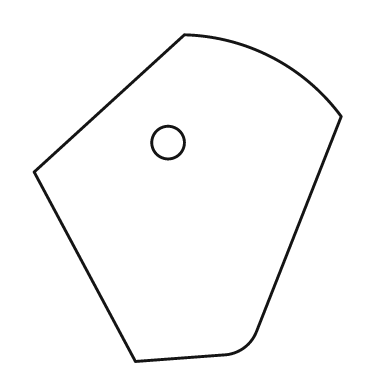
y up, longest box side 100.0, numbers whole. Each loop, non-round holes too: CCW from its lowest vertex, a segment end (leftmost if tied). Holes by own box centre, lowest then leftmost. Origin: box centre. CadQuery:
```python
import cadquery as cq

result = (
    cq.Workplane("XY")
    .moveTo(-16.0, -50.0)
    .lineTo(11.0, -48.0)
    .threePointArc((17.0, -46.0), (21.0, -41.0))
    .lineTo(47.0, 25.0)
    .threePointArc((26.0, 43.0), (-1.0, 50.0))
    .lineTo(-47.0, 8.0)
    .close()
    .moveTo(-6.0, 17.0)
    .circle(5.0)
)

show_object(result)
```